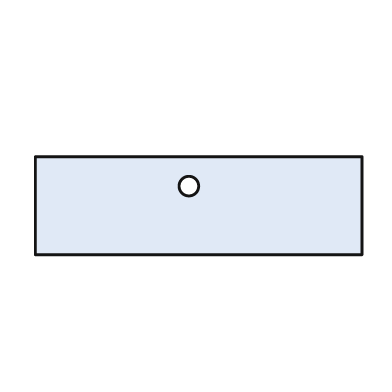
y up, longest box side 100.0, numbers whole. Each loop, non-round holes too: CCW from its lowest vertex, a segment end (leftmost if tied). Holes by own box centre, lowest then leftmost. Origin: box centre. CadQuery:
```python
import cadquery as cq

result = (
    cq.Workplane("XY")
    .moveTo(-50.0, -15.0)
    .lineTo(50.0, -15.0)
    .lineTo(50.0, 15.0)
    .lineTo(-50.0, 15.0)
    .close()
    .moveTo(-3.0, 6.0)
    .circle(3.0)
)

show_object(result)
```